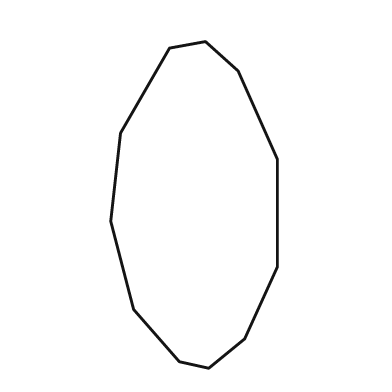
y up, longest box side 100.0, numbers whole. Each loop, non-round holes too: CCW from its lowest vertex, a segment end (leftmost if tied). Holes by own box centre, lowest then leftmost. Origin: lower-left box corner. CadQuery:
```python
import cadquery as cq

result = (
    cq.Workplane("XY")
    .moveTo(30.0, 0.0)
    .lineTo(41.0, 9.0)
    .lineTo(51.0, 31.0)
    .lineTo(51.0, 64.0)
    .lineTo(39.0, 91.0)
    .lineTo(29.0, 100.0)
    .lineTo(18.0, 98.0)
    .lineTo(3.0, 72.0)
    .lineTo(0.0, 45.0)
    .lineTo(7.0, 18.0)
    .lineTo(21.0, 2.0)
    .close()
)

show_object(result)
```